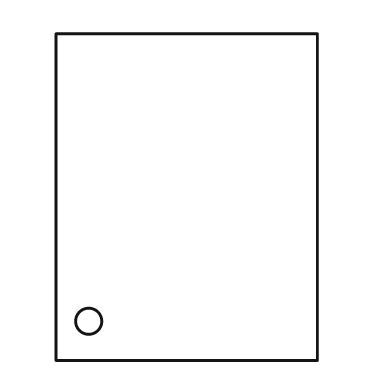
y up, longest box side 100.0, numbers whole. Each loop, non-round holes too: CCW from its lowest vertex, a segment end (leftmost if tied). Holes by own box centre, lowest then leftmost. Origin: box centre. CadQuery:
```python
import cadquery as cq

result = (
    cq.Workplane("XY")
    .moveTo(-40.0, -50.0)
    .lineTo(40.0, -50.0)
    .lineTo(40.0, 50.0)
    .lineTo(-40.0, 50.0)
    .close()
    .moveTo(-30.0, -38.0)
    .circle(4.0)
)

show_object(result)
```